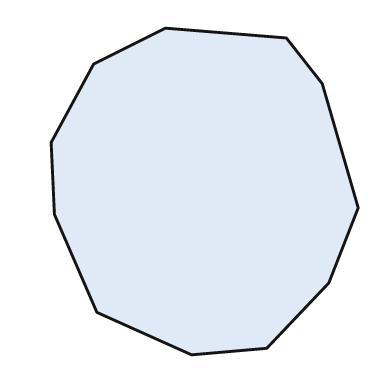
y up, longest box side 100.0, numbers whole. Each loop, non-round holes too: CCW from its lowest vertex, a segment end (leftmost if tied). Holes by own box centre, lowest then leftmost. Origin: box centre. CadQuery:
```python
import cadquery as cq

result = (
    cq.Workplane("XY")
    .moveTo(-4.0, -50.0)
    .lineTo(19.0, -48.0)
    .lineTo(38.0, -28.0)
    .lineTo(47.0, -5.0)
    .lineTo(36.0, 33.0)
    .lineTo(25.0, 47.0)
    .lineTo(-12.0, 50.0)
    .lineTo(-34.0, 39.0)
    .lineTo(-47.0, 15.0)
    .lineTo(-46.0, -7.0)
    .lineTo(-33.0, -37.0)
    .close()
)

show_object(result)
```